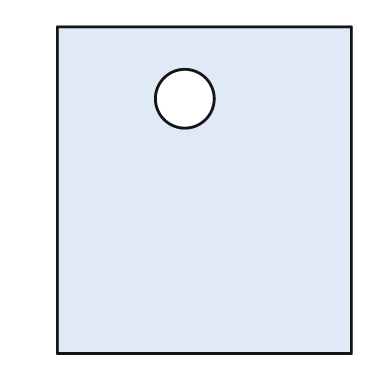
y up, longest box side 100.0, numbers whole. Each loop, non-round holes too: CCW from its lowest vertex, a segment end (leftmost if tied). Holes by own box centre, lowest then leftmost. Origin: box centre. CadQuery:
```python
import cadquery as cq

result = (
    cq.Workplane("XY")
    .moveTo(-45.0, -50.0)
    .lineTo(45.0, -50.0)
    .lineTo(45.0, 50.0)
    .lineTo(-45.0, 50.0)
    .close()
    .moveTo(-6.0, 28.0)
    .circle(9.0)
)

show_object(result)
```